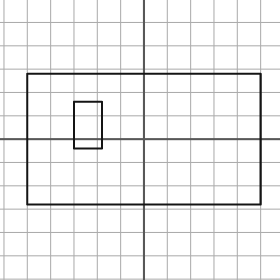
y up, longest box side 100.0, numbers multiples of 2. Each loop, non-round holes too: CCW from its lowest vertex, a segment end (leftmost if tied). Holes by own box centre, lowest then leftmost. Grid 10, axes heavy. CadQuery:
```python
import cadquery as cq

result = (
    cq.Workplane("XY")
    .moveTo(-50.0, -28.0)
    .lineTo(50.0, -28.0)
    .lineTo(50.0, 28.0)
    .lineTo(-50.0, 28.0)
    .close()
    .moveTo(-30.0, -4.0)
    .lineTo(-18.0, -4.0)
    .lineTo(-18.0, 16.0)
    .lineTo(-30.0, 16.0)
    .close()
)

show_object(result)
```